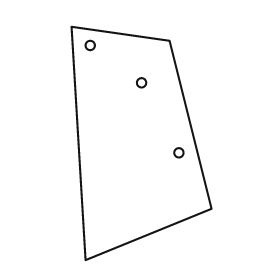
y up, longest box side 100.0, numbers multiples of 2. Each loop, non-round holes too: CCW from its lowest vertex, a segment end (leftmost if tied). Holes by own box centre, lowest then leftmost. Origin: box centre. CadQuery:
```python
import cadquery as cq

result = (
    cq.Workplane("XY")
    .moveTo(-24.0, -50.0)
    .lineTo(30.0, -28.0)
    .lineTo(12.0, 44.0)
    .lineTo(-30.0, 50.0)
    .close()
    .moveTo(16.0, -4.0)
    .circle(2.0)
    .moveTo(0.0, 26.0)
    .circle(2.0)
    .moveTo(-22.0, 42.0)
    .circle(2.0)
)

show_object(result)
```